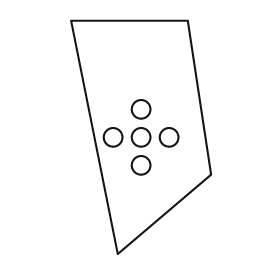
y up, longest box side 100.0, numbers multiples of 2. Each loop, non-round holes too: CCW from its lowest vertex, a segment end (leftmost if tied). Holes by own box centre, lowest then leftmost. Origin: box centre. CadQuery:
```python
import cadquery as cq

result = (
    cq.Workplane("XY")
    .moveTo(-10.0, -50.0)
    .lineTo(30.0, -16.0)
    .lineTo(20.0, 50.0)
    .lineTo(-30.0, 50.0)
    .close()
    .moveTo(0.0, -12.0)
    .circle(4.0)
    .moveTo(-12.0, 0.0)
    .circle(4.0)
    .moveTo(0.0, 0.0)
    .circle(4.0)
    .moveTo(12.0, 0.0)
    .circle(4.0)
    .moveTo(0.0, 12.0)
    .circle(4.0)
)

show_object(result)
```